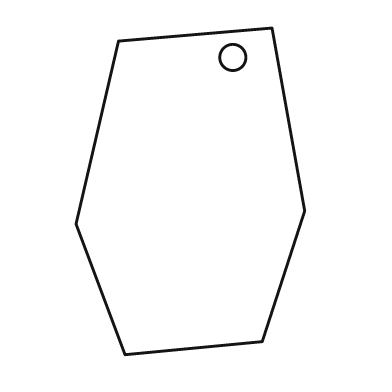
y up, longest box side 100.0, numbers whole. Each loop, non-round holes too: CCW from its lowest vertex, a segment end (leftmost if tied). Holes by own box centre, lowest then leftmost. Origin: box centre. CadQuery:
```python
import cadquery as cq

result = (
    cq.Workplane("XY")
    .moveTo(-20.0, -50.0)
    .lineTo(22.0, -46.0)
    .lineTo(35.0, -6.0)
    .lineTo(25.0, 50.0)
    .lineTo(-22.0, 46.0)
    .lineTo(-35.0, -10.0)
    .close()
    .moveTo(13.0, 41.0)
    .circle(4.0)
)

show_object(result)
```